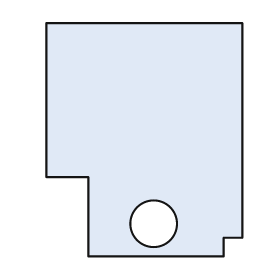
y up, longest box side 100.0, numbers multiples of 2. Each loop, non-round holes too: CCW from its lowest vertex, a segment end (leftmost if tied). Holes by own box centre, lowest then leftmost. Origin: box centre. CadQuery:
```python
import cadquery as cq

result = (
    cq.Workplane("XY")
    .moveTo(-24.0, -50.0)
    .lineTo(34.0, -50.0)
    .lineTo(34.0, -42.0)
    .lineTo(42.0, -42.0)
    .lineTo(42.0, 50.0)
    .lineTo(-42.0, 50.0)
    .lineTo(-42.0, -16.0)
    .lineTo(-24.0, -16.0)
    .close()
    .moveTo(4.0, -36.0)
    .circle(10.0)
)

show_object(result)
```